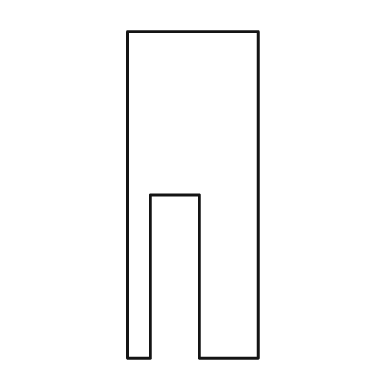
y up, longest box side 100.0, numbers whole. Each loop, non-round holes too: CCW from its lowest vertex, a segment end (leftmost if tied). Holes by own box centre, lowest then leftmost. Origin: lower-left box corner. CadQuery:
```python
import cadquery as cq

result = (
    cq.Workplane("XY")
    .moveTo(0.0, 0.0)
    .lineTo(7.0, 0.0)
    .lineTo(7.0, 50.0)
    .lineTo(22.0, 50.0)
    .lineTo(22.0, 0.0)
    .lineTo(40.0, 0.0)
    .lineTo(40.0, 100.0)
    .lineTo(0.0, 100.0)
    .close()
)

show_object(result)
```